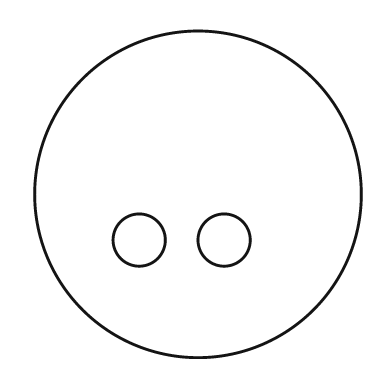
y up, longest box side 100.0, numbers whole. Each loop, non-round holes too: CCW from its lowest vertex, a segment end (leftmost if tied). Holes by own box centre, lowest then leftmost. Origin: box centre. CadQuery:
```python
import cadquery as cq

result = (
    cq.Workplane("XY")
    .moveTo(0.0, 0.0)
    .circle(50.0)
    .moveTo(-18.0, -14.0)
    .circle(8.0)
    .moveTo(8.0, -14.0)
    .circle(8.0)
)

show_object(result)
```